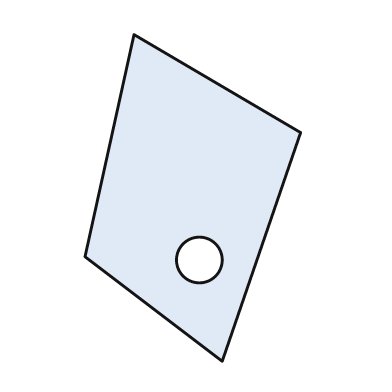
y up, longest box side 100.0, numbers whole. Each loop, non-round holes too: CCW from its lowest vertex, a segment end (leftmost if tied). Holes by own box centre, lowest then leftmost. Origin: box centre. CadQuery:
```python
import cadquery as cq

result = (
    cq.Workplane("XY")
    .moveTo(9.0, -50.0)
    .lineTo(33.0, 20.0)
    .lineTo(-18.0, 50.0)
    .lineTo(-33.0, -18.0)
    .close()
    .moveTo(2.0, -19.0)
    .circle(7.0)
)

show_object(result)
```